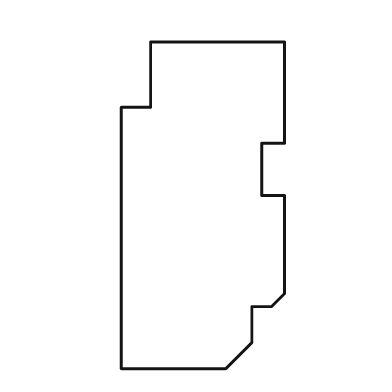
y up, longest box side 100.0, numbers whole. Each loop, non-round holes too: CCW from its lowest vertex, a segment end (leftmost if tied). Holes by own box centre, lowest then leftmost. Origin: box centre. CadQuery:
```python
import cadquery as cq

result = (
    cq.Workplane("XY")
    .moveTo(-25.0, -50.0)
    .lineTo(7.0, -50.0)
    .lineTo(15.0, -42.0)
    .lineTo(15.0, -31.0)
    .lineTo(21.0, -31.0)
    .lineTo(25.0, -27.0)
    .lineTo(25.0, 3.0)
    .lineTo(18.0, 3.0)
    .lineTo(18.0, 19.0)
    .lineTo(25.0, 19.0)
    .lineTo(25.0, 50.0)
    .lineTo(-16.0, 50.0)
    .lineTo(-16.0, 30.0)
    .lineTo(-25.0, 30.0)
    .close()
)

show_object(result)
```